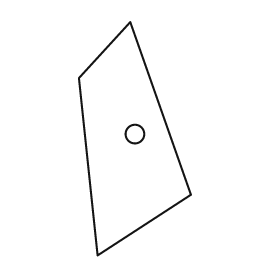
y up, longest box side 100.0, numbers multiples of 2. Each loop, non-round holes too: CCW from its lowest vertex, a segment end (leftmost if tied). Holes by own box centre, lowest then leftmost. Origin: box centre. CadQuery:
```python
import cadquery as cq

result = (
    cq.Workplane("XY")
    .moveTo(-16.0, -50.0)
    .lineTo(24.0, -24.0)
    .lineTo(-2.0, 50.0)
    .lineTo(-24.0, 26.0)
    .close()
    .moveTo(0.0, 2.0)
    .circle(4.0)
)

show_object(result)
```